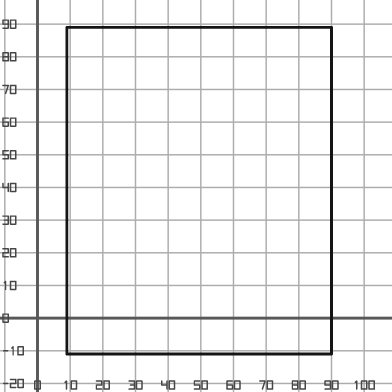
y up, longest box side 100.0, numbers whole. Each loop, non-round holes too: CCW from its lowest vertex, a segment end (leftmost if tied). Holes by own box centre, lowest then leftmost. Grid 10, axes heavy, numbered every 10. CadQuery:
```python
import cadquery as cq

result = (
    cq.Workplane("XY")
    .moveTo(9.0, -11.0)
    .lineTo(90.0, -11.0)
    .lineTo(90.0, 89.0)
    .lineTo(9.0, 89.0)
    .close()
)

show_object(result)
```